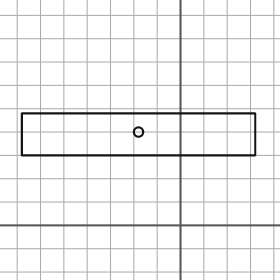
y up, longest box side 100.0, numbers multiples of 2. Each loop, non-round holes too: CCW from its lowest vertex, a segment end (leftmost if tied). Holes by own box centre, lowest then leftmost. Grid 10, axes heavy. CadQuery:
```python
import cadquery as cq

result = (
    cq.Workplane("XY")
    .moveTo(-68.0, 30.0)
    .lineTo(32.0, 30.0)
    .lineTo(32.0, 48.0)
    .lineTo(-68.0, 48.0)
    .close()
    .moveTo(-18.0, 40.0)
    .circle(2.0)
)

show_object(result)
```